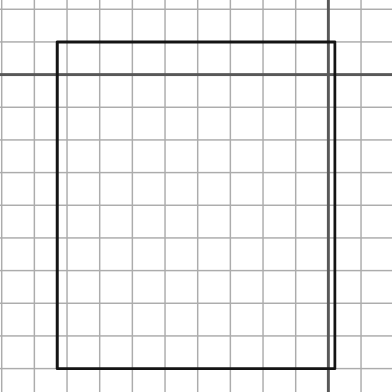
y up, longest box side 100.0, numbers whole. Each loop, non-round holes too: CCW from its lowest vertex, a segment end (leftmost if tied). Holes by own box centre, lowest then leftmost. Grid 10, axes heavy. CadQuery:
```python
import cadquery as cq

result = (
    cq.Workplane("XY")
    .moveTo(-83.0, -90.0)
    .lineTo(2.0, -90.0)
    .lineTo(2.0, 10.0)
    .lineTo(-83.0, 10.0)
    .close()
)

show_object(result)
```